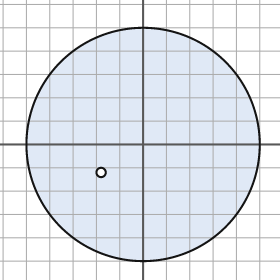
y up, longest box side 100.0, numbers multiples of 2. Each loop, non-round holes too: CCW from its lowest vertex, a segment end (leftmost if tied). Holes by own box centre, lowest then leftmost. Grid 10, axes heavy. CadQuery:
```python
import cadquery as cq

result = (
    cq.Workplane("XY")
    .moveTo(0.0, 0.0)
    .circle(50.0)
    .moveTo(-18.0, -12.0)
    .circle(2.0)
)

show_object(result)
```